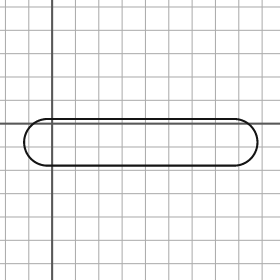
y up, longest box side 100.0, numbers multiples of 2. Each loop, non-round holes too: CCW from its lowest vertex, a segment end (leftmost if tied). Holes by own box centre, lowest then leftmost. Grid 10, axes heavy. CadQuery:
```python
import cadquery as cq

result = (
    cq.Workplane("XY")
    .moveTo(-2.0, -18.0)
    .lineTo(78.0, -18.0)
    .threePointArc((88.0, -8.0), (78.0, 2.0))
    .lineTo(-2.0, 2.0)
    .threePointArc((-12.0, -8.0), (-2.0, -18.0))
    .close()
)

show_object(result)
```